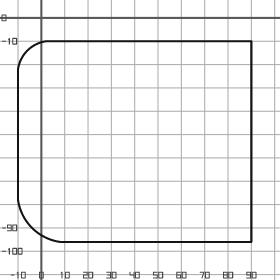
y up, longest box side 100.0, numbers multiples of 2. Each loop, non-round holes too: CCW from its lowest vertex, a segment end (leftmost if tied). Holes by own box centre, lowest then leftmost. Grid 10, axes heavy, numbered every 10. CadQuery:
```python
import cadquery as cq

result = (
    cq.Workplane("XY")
    .moveTo(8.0, -96.0)
    .lineTo(90.0, -96.0)
    .lineTo(90.0, -10.0)
    .lineTo(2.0, -10.0)
    .threePointArc((-6.0, -14.0), (-10.0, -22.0))
    .lineTo(-10.0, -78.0)
    .threePointArc((-4.0, -90.0), (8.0, -96.0))
    .close()
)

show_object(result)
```